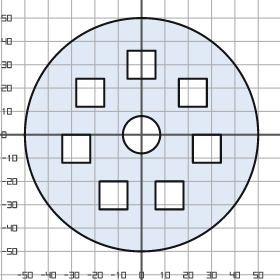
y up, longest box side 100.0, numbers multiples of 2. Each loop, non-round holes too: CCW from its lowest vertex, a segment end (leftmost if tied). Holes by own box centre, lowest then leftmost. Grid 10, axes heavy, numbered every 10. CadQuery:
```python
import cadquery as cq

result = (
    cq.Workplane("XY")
    .moveTo(0.0, 0.0)
    .circle(50.0)
    .moveTo(-18.0, -32.0)
    .lineTo(-6.0, -32.0)
    .lineTo(-6.0, -20.0)
    .lineTo(-18.0, -20.0)
    .close()
    .moveTo(6.0, -32.0)
    .lineTo(18.0, -32.0)
    .lineTo(18.0, -20.0)
    .lineTo(6.0, -20.0)
    .close()
    .moveTo(-34.0, -12.0)
    .lineTo(-22.0, -12.0)
    .lineTo(-22.0, 0.0)
    .lineTo(-34.0, 0.0)
    .close()
    .moveTo(22.0, -12.0)
    .lineTo(34.0, -12.0)
    .lineTo(34.0, 0.0)
    .lineTo(22.0, 0.0)
    .close()
    .moveTo(0.0, 0.0)
    .circle(8.0)
    .moveTo(-28.0, 12.0)
    .lineTo(-16.0, 12.0)
    .lineTo(-16.0, 24.0)
    .lineTo(-28.0, 24.0)
    .close()
    .moveTo(16.0, 12.0)
    .lineTo(28.0, 12.0)
    .lineTo(28.0, 24.0)
    .lineTo(16.0, 24.0)
    .close()
    .moveTo(-6.0, 24.0)
    .lineTo(6.0, 24.0)
    .lineTo(6.0, 36.0)
    .lineTo(-6.0, 36.0)
    .close()
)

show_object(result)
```